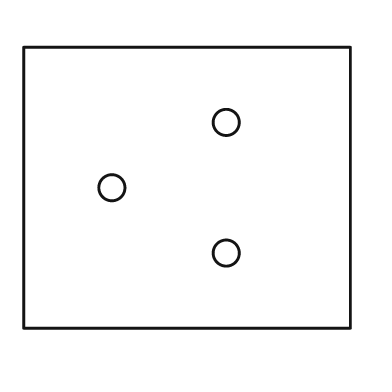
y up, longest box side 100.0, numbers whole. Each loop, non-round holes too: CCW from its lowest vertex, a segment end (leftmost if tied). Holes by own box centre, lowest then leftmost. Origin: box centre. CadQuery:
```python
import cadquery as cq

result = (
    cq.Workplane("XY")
    .moveTo(-50.0, -43.0)
    .lineTo(50.0, -43.0)
    .lineTo(50.0, 43.0)
    .lineTo(-50.0, 43.0)
    .close()
    .moveTo(12.0, -20.0)
    .circle(4.0)
    .moveTo(-23.0, 0.0)
    .circle(4.0)
    .moveTo(12.0, 20.0)
    .circle(4.0)
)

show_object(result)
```